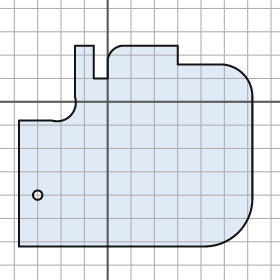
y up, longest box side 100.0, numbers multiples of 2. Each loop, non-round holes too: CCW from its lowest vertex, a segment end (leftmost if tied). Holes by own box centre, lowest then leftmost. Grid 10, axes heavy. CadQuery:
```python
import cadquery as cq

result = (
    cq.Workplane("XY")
    .moveTo(-38.0, -62.0)
    .lineTo(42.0, -62.0)
    .threePointArc((56.0, -56.0), (62.0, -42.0))
    .lineTo(62.0, 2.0)
    .threePointArc((58.0, 12.0), (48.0, 16.0))
    .lineTo(30.0, 16.0)
    .lineTo(30.0, 24.0)
    .lineTo(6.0, 24.0)
    .threePointArc((2.0, 22.0), (0.0, 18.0))
    .lineTo(0.0, 10.0)
    .lineTo(-6.0, 10.0)
    .lineTo(-6.0, 24.0)
    .lineTo(-14.0, 24.0)
    .lineTo(-14.0, 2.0)
    .threePointArc((-16.0, -6.0), (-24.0, -8.0))
    .lineTo(-38.0, -8.0)
    .close()
    .moveTo(-30.0, -40.0)
    .circle(2.0)
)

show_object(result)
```